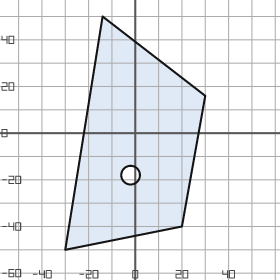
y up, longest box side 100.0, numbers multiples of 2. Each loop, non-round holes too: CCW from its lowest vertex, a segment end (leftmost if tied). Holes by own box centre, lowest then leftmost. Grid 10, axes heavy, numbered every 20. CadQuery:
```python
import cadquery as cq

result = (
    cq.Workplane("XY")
    .moveTo(-30.0, -50.0)
    .lineTo(20.0, -40.0)
    .lineTo(30.0, 16.0)
    .lineTo(-14.0, 50.0)
    .close()
    .moveTo(-2.0, -18.0)
    .circle(4.0)
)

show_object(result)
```